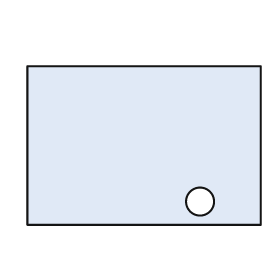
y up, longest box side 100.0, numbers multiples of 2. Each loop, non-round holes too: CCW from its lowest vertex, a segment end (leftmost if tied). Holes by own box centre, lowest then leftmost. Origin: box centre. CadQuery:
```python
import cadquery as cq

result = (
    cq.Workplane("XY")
    .moveTo(-50.0, -34.0)
    .lineTo(50.0, -34.0)
    .lineTo(50.0, 34.0)
    .lineTo(-50.0, 34.0)
    .close()
    .moveTo(24.0, -24.0)
    .circle(6.0)
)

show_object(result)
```